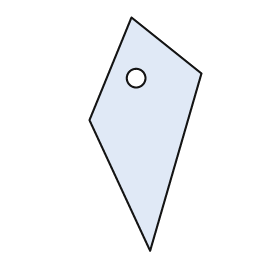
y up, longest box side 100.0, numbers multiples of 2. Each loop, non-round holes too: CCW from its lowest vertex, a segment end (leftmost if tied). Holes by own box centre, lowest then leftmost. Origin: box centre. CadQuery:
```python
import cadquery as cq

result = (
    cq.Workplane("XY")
    .moveTo(2.0, -50.0)
    .lineTo(24.0, 26.0)
    .lineTo(-6.0, 50.0)
    .lineTo(-24.0, 6.0)
    .close()
    .moveTo(-4.0, 24.0)
    .circle(4.0)
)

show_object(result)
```